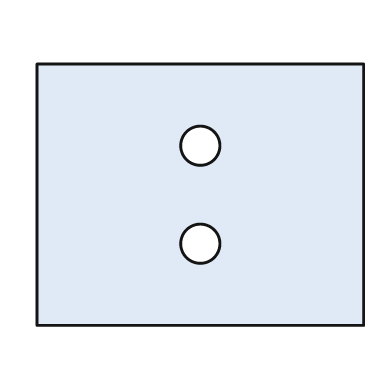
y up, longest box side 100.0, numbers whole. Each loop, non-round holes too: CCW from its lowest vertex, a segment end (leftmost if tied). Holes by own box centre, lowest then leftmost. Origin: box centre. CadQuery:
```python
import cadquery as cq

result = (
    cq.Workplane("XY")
    .moveTo(-50.0, -40.0)
    .lineTo(50.0, -40.0)
    .lineTo(50.0, 40.0)
    .lineTo(-50.0, 40.0)
    .close()
    .moveTo(0.0, -15.0)
    .circle(6.0)
    .moveTo(0.0, 15.0)
    .circle(6.0)
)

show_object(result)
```